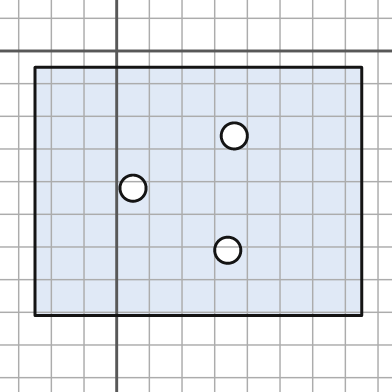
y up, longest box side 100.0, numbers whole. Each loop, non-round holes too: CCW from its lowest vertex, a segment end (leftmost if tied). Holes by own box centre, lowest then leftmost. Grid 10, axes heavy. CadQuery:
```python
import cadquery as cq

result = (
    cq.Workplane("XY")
    .moveTo(-25.0, -81.0)
    .lineTo(75.0, -81.0)
    .lineTo(75.0, -5.0)
    .lineTo(-25.0, -5.0)
    .close()
    .moveTo(34.0, -61.0)
    .circle(4.0)
    .moveTo(5.0, -42.0)
    .circle(4.0)
    .moveTo(36.0, -26.0)
    .circle(4.0)
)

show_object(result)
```